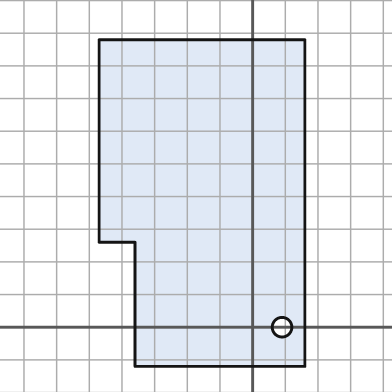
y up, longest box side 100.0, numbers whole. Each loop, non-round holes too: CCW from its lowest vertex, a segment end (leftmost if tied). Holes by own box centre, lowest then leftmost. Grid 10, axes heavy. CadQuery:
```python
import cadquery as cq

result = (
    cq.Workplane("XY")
    .moveTo(-36.0, -12.0)
    .lineTo(16.0, -12.0)
    .lineTo(16.0, 88.0)
    .lineTo(-47.0, 88.0)
    .lineTo(-47.0, 26.0)
    .lineTo(-36.0, 26.0)
    .close()
    .moveTo(9.0, 0.0)
    .circle(3.0)
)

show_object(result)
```